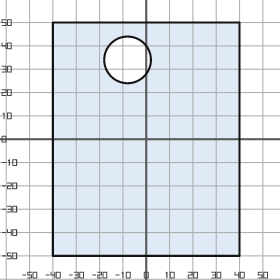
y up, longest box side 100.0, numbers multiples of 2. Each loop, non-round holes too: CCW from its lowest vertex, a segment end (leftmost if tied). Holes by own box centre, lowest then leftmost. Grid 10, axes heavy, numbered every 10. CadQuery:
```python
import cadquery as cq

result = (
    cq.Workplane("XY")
    .moveTo(-40.0, -50.0)
    .lineTo(40.0, -50.0)
    .lineTo(40.0, 50.0)
    .lineTo(-40.0, 50.0)
    .close()
    .moveTo(-8.0, 34.0)
    .circle(10.0)
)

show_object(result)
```